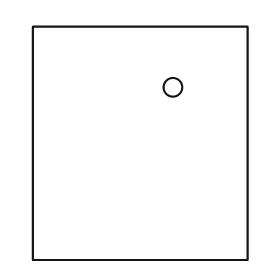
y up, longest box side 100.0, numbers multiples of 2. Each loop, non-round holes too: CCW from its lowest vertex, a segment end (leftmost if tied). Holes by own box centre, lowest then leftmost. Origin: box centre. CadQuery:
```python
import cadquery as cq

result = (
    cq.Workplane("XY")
    .moveTo(-46.0, -50.0)
    .lineTo(46.0, -50.0)
    .lineTo(46.0, 50.0)
    .lineTo(-46.0, 50.0)
    .close()
    .moveTo(14.0, 24.0)
    .circle(4.0)
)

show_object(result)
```